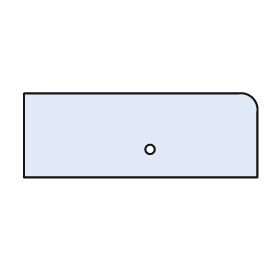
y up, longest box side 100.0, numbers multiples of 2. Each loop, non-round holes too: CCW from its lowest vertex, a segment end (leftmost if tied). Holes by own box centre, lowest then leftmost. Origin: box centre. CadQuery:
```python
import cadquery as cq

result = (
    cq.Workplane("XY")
    .moveTo(-50.0, -18.0)
    .lineTo(50.0, -18.0)
    .lineTo(50.0, 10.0)
    .threePointArc((48.0, 16.0), (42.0, 18.0))
    .lineTo(-50.0, 18.0)
    .close()
    .moveTo(4.0, -6.0)
    .circle(2.0)
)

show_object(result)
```